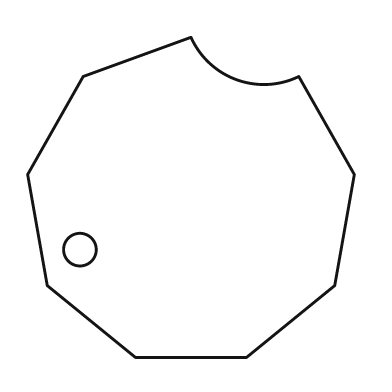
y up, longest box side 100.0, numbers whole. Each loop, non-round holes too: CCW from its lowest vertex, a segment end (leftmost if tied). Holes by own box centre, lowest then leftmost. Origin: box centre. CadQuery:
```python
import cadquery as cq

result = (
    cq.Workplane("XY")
    .moveTo(-17.0, -49.0)
    .lineTo(17.0, -49.0)
    .lineTo(44.0, -27.0)
    .lineTo(50.0, 7.0)
    .lineTo(33.0, 37.0)
    .threePointArc((14.0, 36.0), (0.0, 49.0))
    .lineTo(-33.0, 37.0)
    .lineTo(-50.0, 7.0)
    .lineTo(-44.0, -27.0)
    .close()
    .moveTo(-34.0, -16.0)
    .circle(5.0)
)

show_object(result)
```